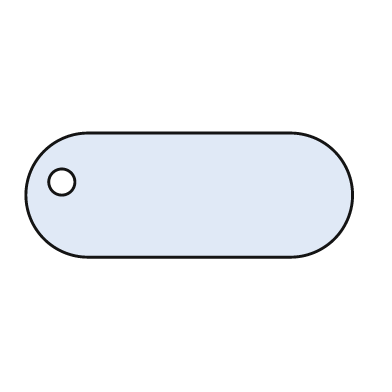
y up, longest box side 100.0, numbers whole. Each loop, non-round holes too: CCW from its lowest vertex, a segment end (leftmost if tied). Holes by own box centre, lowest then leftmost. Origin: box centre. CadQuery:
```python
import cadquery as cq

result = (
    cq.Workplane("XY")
    .moveTo(-31.0, -19.0)
    .lineTo(31.0, -19.0)
    .threePointArc((50.0, 0.0), (31.0, 19.0))
    .lineTo(-31.0, 19.0)
    .threePointArc((-50.0, 0.0), (-31.0, -19.0))
    .close()
    .moveTo(-39.0, 4.0)
    .circle(4.0)
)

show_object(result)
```